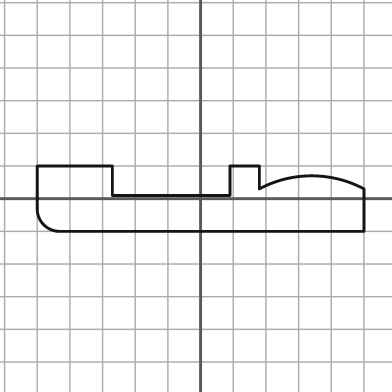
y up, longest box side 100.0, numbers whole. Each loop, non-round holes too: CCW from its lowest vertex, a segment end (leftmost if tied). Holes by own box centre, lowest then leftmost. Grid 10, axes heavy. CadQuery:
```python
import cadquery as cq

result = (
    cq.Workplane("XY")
    .moveTo(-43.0, -10.0)
    .lineTo(50.0, -10.0)
    .lineTo(50.0, 3.0)
    .threePointArc((34.0, 7.0), (18.0, 3.0))
    .lineTo(18.0, 10.0)
    .lineTo(9.0, 10.0)
    .lineTo(9.0, 1.0)
    .lineTo(-27.0, 1.0)
    .lineTo(-27.0, 10.0)
    .lineTo(-50.0, 10.0)
    .lineTo(-50.0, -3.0)
    .threePointArc((-48.0, -8.0), (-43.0, -10.0))
    .close()
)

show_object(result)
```